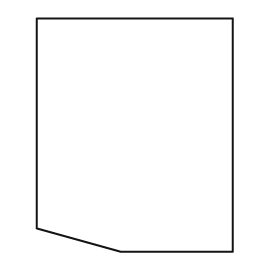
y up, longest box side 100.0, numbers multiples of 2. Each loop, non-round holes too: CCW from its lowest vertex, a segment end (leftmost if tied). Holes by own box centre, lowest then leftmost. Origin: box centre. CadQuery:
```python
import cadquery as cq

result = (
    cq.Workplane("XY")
    .moveTo(-6.0, -50.0)
    .lineTo(42.0, -50.0)
    .lineTo(42.0, 50.0)
    .lineTo(-42.0, 50.0)
    .lineTo(-42.0, -40.0)
    .close()
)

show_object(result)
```